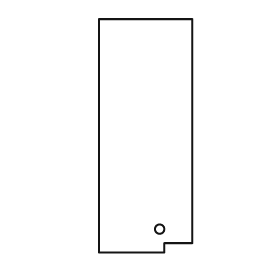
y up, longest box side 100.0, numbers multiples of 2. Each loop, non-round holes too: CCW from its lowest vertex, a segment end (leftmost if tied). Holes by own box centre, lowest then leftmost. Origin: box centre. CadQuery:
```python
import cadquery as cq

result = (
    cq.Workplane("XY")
    .moveTo(-20.0, -50.0)
    .lineTo(8.0, -50.0)
    .lineTo(8.0, -46.0)
    .lineTo(20.0, -46.0)
    .lineTo(20.0, 50.0)
    .lineTo(-20.0, 50.0)
    .close()
    .moveTo(6.0, -40.0)
    .circle(2.0)
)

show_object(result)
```